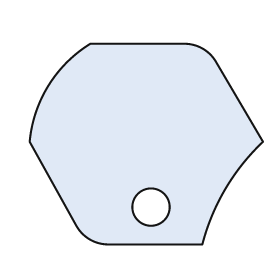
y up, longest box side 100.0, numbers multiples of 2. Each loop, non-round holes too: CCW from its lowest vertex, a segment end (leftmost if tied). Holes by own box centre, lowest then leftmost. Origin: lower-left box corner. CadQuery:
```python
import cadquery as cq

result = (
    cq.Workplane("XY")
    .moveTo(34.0, 0.0)
    .lineTo(74.0, 0.0)
    .threePointArc((84.0, 24.0), (100.0, 44.0))
    .lineTo(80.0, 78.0)
    .threePointArc((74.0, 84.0), (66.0, 86.0))
    .lineTo(26.0, 86.0)
    .threePointArc((8.0, 68.0), (0.0, 44.0))
    .lineTo(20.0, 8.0)
    .threePointArc((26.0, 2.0), (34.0, 0.0))
    .close()
    .moveTo(52.0, 16.0)
    .circle(8.0)
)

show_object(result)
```